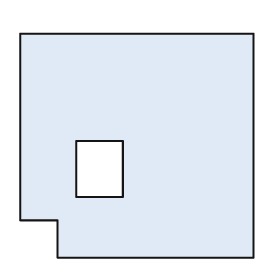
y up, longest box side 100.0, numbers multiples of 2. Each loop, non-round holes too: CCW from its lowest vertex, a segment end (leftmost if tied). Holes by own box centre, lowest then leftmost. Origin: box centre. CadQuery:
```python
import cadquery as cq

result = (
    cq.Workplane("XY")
    .moveTo(-34.0, -48.0)
    .lineTo(50.0, -48.0)
    .lineTo(50.0, 48.0)
    .lineTo(-50.0, 48.0)
    .lineTo(-50.0, -32.0)
    .lineTo(-34.0, -32.0)
    .close()
    .moveTo(-26.0, -22.0)
    .lineTo(-6.0, -22.0)
    .lineTo(-6.0, 2.0)
    .lineTo(-26.0, 2.0)
    .close()
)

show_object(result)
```